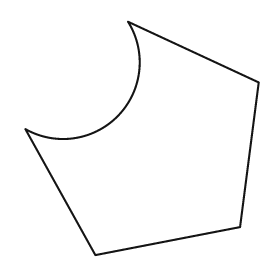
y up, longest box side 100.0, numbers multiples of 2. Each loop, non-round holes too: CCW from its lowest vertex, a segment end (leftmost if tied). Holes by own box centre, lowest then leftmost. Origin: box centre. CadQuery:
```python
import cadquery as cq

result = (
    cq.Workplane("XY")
    .moveTo(-20.0, -50.0)
    .lineTo(42.0, -38.0)
    .lineTo(50.0, 24.0)
    .lineTo(-6.0, 50.0)
    .threePointArc((-10.0, 10.0), (-50.0, 4.0))
    .close()
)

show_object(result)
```